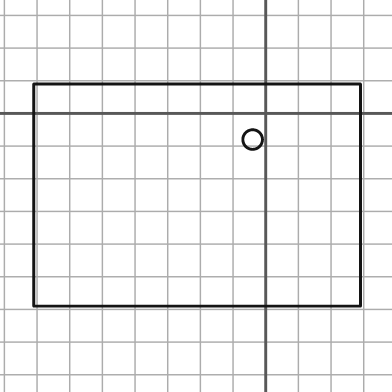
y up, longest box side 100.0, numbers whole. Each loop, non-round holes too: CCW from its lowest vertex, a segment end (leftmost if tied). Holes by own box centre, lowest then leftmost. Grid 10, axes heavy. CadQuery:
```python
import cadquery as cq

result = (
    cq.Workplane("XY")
    .moveTo(-71.0, -59.0)
    .lineTo(29.0, -59.0)
    .lineTo(29.0, 9.0)
    .lineTo(-71.0, 9.0)
    .close()
    .moveTo(-4.0, -8.0)
    .circle(3.0)
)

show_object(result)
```